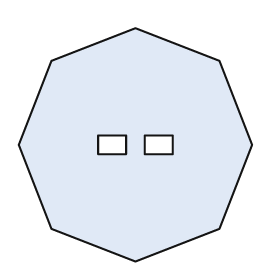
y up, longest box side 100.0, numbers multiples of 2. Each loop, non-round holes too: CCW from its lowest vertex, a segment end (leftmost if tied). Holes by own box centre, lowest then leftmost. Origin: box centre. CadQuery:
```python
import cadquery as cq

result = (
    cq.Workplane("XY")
    .moveTo(0.0, -50.0)
    .lineTo(36.0, -36.0)
    .lineTo(50.0, 0.0)
    .lineTo(36.0, 36.0)
    .lineTo(0.0, 50.0)
    .lineTo(-36.0, 36.0)
    .lineTo(-50.0, 0.0)
    .lineTo(-36.0, -36.0)
    .close()
    .moveTo(-16.0, -4.0)
    .lineTo(-4.0, -4.0)
    .lineTo(-4.0, 4.0)
    .lineTo(-16.0, 4.0)
    .close()
    .moveTo(4.0, -4.0)
    .lineTo(16.0, -4.0)
    .lineTo(16.0, 4.0)
    .lineTo(4.0, 4.0)
    .close()
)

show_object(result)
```